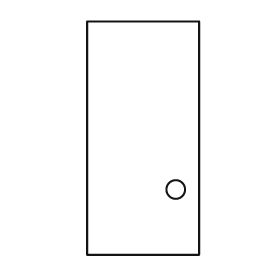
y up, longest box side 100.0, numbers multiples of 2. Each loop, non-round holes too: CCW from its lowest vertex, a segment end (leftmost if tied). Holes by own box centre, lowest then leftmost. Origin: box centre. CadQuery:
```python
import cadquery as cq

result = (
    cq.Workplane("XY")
    .moveTo(-24.0, -50.0)
    .lineTo(24.0, -50.0)
    .lineTo(24.0, 50.0)
    .lineTo(-24.0, 50.0)
    .close()
    .moveTo(14.0, -22.0)
    .circle(4.0)
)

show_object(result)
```